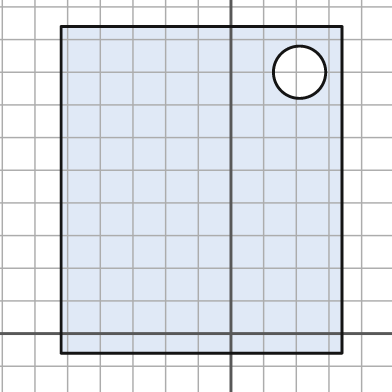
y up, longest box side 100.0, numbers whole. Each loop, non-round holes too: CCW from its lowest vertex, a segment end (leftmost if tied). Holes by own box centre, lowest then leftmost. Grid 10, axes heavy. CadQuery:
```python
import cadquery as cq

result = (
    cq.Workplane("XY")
    .moveTo(-52.0, -6.0)
    .lineTo(34.0, -6.0)
    .lineTo(34.0, 94.0)
    .lineTo(-52.0, 94.0)
    .close()
    .moveTo(21.0, 80.0)
    .circle(8.0)
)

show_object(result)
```